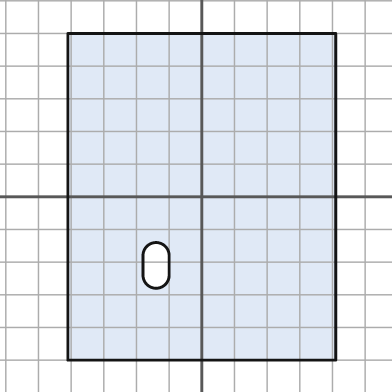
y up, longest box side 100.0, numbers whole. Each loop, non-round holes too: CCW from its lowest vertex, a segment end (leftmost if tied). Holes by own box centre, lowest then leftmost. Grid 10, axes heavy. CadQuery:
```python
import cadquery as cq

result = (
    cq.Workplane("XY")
    .moveTo(-41.0, -50.0)
    .lineTo(41.0, -50.0)
    .lineTo(41.0, 50.0)
    .lineTo(-41.0, 50.0)
    .close()
    .moveTo(-18.0, -24.0)
    .threePointArc((-14.0, -28.0), (-10.0, -24.0))
    .lineTo(-10.0, -18.0)
    .threePointArc((-14.0, -14.0), (-18.0, -18.0))
    .close()
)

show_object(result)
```